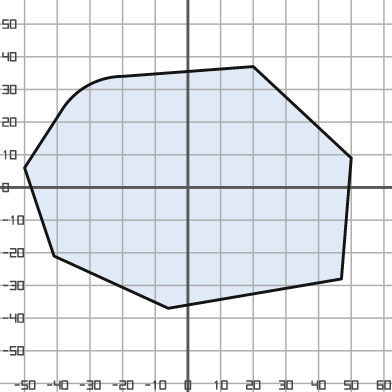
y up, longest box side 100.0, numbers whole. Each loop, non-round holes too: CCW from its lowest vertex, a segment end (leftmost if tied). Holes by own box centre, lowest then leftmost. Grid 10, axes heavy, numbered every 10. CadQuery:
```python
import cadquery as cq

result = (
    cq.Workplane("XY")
    .moveTo(-6.0, -37.0)
    .lineTo(47.0, -28.0)
    .lineTo(50.0, 9.0)
    .lineTo(20.0, 37.0)
    .lineTo(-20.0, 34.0)
    .threePointArc((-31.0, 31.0), (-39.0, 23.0))
    .lineTo(-50.0, 6.0)
    .lineTo(-41.0, -21.0)
    .close()
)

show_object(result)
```